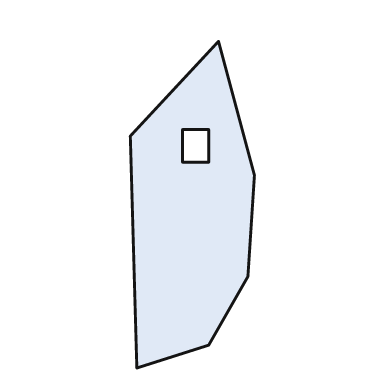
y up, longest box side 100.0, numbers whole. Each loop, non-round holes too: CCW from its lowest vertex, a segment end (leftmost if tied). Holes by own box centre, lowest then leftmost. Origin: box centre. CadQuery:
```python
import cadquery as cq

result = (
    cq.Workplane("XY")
    .moveTo(-17.0, -50.0)
    .lineTo(5.0, -43.0)
    .lineTo(17.0, -22.0)
    .lineTo(19.0, 9.0)
    .lineTo(8.0, 50.0)
    .lineTo(-19.0, 21.0)
    .close()
    .moveTo(-3.0, 13.0)
    .lineTo(5.0, 13.0)
    .lineTo(5.0, 23.0)
    .lineTo(-3.0, 23.0)
    .close()
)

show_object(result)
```